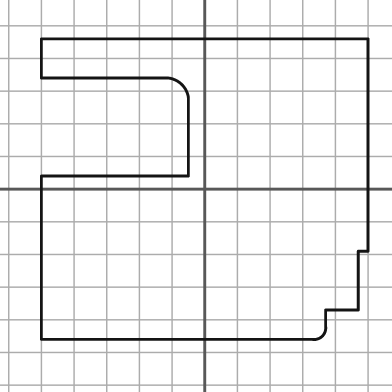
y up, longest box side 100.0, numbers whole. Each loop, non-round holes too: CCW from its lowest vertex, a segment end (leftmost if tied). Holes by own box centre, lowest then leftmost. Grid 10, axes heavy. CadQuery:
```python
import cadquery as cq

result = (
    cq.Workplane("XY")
    .moveTo(-50.0, -46.0)
    .lineTo(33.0, -46.0)
    .threePointArc((36.0, -45.0), (37.0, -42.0))
    .lineTo(37.0, -37.0)
    .lineTo(47.0, -37.0)
    .lineTo(47.0, -19.0)
    .lineTo(50.0, -19.0)
    .lineTo(50.0, 46.0)
    .lineTo(-50.0, 46.0)
    .lineTo(-50.0, 34.0)
    .lineTo(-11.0, 34.0)
    .threePointArc((-7.0, 32.0), (-5.0, 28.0))
    .lineTo(-5.0, 4.0)
    .lineTo(-50.0, 4.0)
    .close()
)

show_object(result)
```